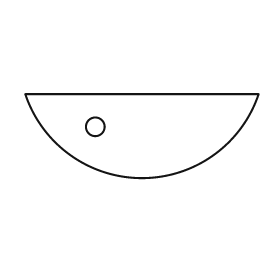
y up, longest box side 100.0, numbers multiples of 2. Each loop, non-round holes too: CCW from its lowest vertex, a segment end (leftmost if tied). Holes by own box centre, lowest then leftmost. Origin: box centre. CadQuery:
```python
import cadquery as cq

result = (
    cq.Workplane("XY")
    .moveTo(-50.0, 18.0)
    .threePointArc((0.0, -18.0), (50.0, 18.0))
    .close()
    .moveTo(-20.0, 4.0)
    .circle(4.0)
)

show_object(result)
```